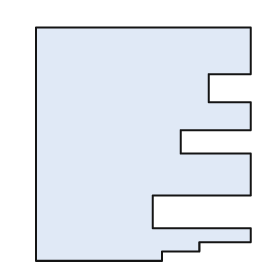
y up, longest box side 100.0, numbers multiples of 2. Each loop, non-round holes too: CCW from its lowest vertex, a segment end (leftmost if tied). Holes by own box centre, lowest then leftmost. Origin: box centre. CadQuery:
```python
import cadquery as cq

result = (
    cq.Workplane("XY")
    .moveTo(-46.0, -50.0)
    .lineTo(8.0, -50.0)
    .lineTo(8.0, -46.0)
    .lineTo(24.0, -46.0)
    .lineTo(24.0, -42.0)
    .lineTo(46.0, -42.0)
    .lineTo(46.0, -36.0)
    .lineTo(4.0, -36.0)
    .lineTo(4.0, -22.0)
    .lineTo(46.0, -22.0)
    .lineTo(46.0, -4.0)
    .lineTo(16.0, -4.0)
    .lineTo(16.0, 6.0)
    .lineTo(46.0, 6.0)
    .lineTo(46.0, 18.0)
    .lineTo(28.0, 18.0)
    .lineTo(28.0, 30.0)
    .lineTo(46.0, 30.0)
    .lineTo(46.0, 50.0)
    .lineTo(-46.0, 50.0)
    .close()
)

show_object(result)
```